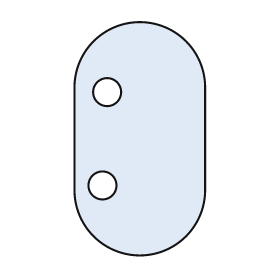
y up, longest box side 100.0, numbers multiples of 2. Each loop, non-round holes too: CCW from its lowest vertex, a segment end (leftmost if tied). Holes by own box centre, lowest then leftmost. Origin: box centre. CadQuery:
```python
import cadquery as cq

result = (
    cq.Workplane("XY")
    .moveTo(-28.0, -22.0)
    .threePointArc((0.0, -50.0), (28.0, -22.0))
    .lineTo(28.0, 22.0)
    .threePointArc((0.0, 50.0), (-28.0, 22.0))
    .close()
    .moveTo(-16.0, -20.0)
    .circle(6.0)
    .moveTo(-14.0, 20.0)
    .circle(6.0)
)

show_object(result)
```